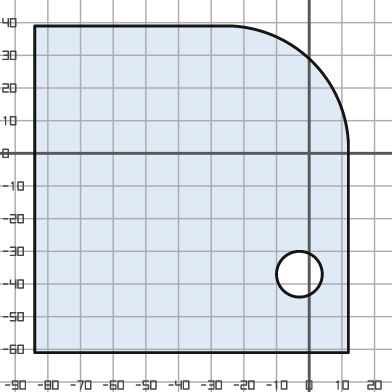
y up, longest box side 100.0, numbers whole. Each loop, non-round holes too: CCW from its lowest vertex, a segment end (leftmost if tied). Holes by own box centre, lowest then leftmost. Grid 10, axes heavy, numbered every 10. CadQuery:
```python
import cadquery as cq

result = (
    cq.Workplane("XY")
    .moveTo(-84.0, -61.0)
    .lineTo(12.0, -61.0)
    .lineTo(12.0, 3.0)
    .threePointArc((1.0, 28.0), (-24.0, 39.0))
    .lineTo(-84.0, 39.0)
    .close()
    .moveTo(-3.0, -37.0)
    .circle(7.0)
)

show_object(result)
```